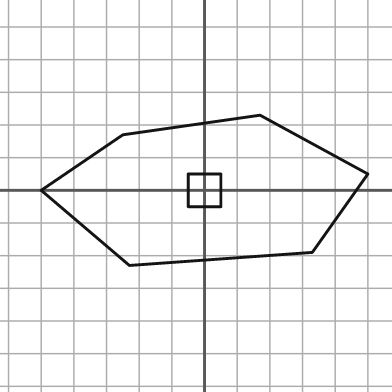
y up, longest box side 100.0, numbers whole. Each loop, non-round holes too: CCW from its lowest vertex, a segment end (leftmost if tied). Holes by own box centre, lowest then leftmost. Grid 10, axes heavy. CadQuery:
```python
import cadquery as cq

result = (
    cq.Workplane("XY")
    .moveTo(-23.0, -23.0)
    .lineTo(33.0, -19.0)
    .lineTo(50.0, 5.0)
    .lineTo(17.0, 23.0)
    .lineTo(-25.0, 17.0)
    .lineTo(-50.0, 0.0)
    .close()
    .moveTo(-5.0, -5.0)
    .lineTo(5.0, -5.0)
    .lineTo(5.0, 5.0)
    .lineTo(-5.0, 5.0)
    .close()
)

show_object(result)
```